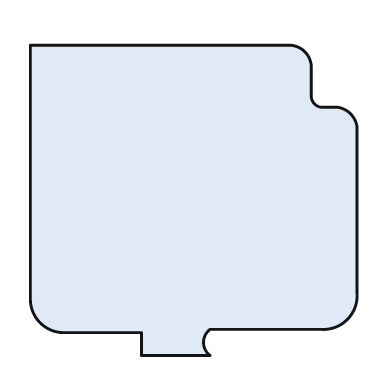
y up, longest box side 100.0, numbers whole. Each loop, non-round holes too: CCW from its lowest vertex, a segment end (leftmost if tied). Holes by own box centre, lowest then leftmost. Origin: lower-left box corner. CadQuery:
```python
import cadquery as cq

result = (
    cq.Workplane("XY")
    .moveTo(34.0, 0.0)
    .lineTo(55.0, 0.0)
    .threePointArc((53.0, 4.0), (55.0, 8.0))
    .lineTo(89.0, 8.0)
    .threePointArc((97.0, 11.0), (100.0, 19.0))
    .lineTo(100.0, 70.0)
    .threePointArc((98.0, 74.0), (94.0, 76.0))
    .lineTo(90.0, 76.0)
    .threePointArc((87.0, 77.0), (86.0, 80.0))
    .lineTo(86.0, 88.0)
    .threePointArc((84.0, 93.0), (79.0, 95.0))
    .lineTo(0.0, 95.0)
    .lineTo(0.0, 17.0)
    .threePointArc((3.0, 10.0), (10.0, 7.0))
    .lineTo(34.0, 7.0)
    .close()
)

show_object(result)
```